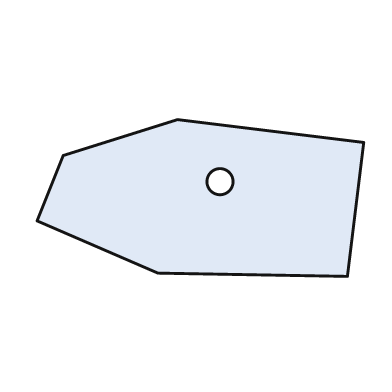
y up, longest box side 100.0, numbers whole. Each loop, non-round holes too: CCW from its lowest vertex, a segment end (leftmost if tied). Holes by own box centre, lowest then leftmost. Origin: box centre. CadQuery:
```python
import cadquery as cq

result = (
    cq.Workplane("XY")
    .moveTo(45.0, -24.0)
    .lineTo(50.0, 17.0)
    .lineTo(-7.0, 24.0)
    .lineTo(-42.0, 13.0)
    .lineTo(-50.0, -7.0)
    .lineTo(-13.0, -23.0)
    .close()
    .moveTo(6.0, 5.0)
    .circle(4.0)
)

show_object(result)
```